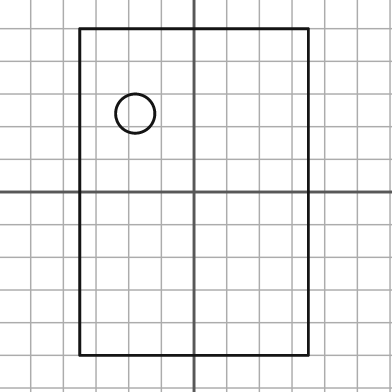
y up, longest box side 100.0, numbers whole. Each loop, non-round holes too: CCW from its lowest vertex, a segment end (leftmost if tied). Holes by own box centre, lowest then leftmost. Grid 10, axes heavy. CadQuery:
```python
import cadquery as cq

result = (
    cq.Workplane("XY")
    .moveTo(-35.0, -50.0)
    .lineTo(35.0, -50.0)
    .lineTo(35.0, 50.0)
    .lineTo(-35.0, 50.0)
    .close()
    .moveTo(-18.0, 24.0)
    .circle(6.0)
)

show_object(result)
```